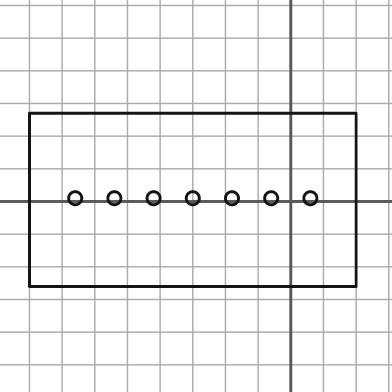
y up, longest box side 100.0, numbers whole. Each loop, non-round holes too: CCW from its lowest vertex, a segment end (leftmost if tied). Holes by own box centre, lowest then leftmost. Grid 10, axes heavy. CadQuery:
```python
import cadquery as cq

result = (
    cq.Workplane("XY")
    .moveTo(-80.0, -26.0)
    .lineTo(20.0, -26.0)
    .lineTo(20.0, 27.0)
    .lineTo(-80.0, 27.0)
    .close()
    .moveTo(-66.0, 1.0)
    .circle(2.0)
    .moveTo(-54.0, 1.0)
    .circle(2.0)
    .moveTo(-42.0, 1.0)
    .circle(2.0)
    .moveTo(-30.0, 1.0)
    .circle(2.0)
    .moveTo(-18.0, 1.0)
    .circle(2.0)
    .moveTo(-6.0, 1.0)
    .circle(2.0)
    .moveTo(6.0, 1.0)
    .circle(2.0)
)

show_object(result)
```